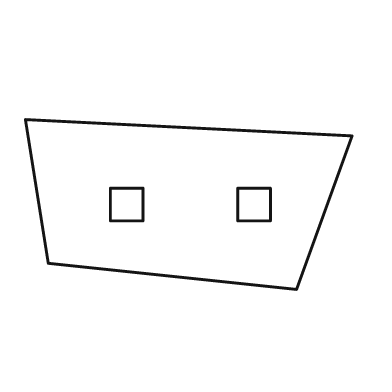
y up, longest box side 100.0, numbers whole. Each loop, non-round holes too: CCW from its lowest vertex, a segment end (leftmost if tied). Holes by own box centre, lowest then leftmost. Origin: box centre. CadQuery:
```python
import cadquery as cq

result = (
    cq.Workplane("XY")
    .moveTo(33.0, -26.0)
    .lineTo(50.0, 21.0)
    .lineTo(-50.0, 26.0)
    .lineTo(-43.0, -18.0)
    .close()
    .moveTo(-24.0, -5.0)
    .lineTo(-14.0, -5.0)
    .lineTo(-14.0, 5.0)
    .lineTo(-24.0, 5.0)
    .close()
    .moveTo(15.0, -5.0)
    .lineTo(25.0, -5.0)
    .lineTo(25.0, 5.0)
    .lineTo(15.0, 5.0)
    .close()
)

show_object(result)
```